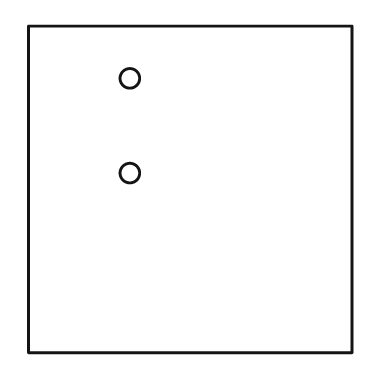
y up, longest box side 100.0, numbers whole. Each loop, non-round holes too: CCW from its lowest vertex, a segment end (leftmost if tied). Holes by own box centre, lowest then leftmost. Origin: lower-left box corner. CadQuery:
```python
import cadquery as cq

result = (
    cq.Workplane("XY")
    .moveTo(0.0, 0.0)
    .lineTo(99.0, 0.0)
    .lineTo(99.0, 100.0)
    .lineTo(0.0, 100.0)
    .close()
    .moveTo(31.0, 55.0)
    .circle(3.0)
    .moveTo(31.0, 84.0)
    .circle(3.0)
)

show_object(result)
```